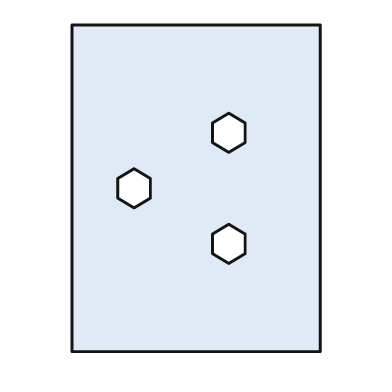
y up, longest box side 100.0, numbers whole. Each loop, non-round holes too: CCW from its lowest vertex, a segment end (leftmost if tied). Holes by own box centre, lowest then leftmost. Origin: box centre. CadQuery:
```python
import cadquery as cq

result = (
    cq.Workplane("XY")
    .moveTo(-38.0, -50.0)
    .lineTo(38.0, -50.0)
    .lineTo(38.0, 50.0)
    .lineTo(-38.0, 50.0)
    .close()
    .moveTo(10.0, -23.0)
    .lineTo(15.0, -20.0)
    .lineTo(15.0, -14.0)
    .lineTo(10.0, -11.0)
    .lineTo(5.0, -14.0)
    .lineTo(5.0, -20.0)
    .close()
    .moveTo(-19.0, -6.0)
    .lineTo(-14.0, -3.0)
    .lineTo(-14.0, 3.0)
    .lineTo(-19.0, 6.0)
    .lineTo(-24.0, 3.0)
    .lineTo(-24.0, -3.0)
    .close()
    .moveTo(10.0, 11.0)
    .lineTo(15.0, 14.0)
    .lineTo(15.0, 20.0)
    .lineTo(10.0, 23.0)
    .lineTo(5.0, 20.0)
    .lineTo(5.0, 14.0)
    .close()
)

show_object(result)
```